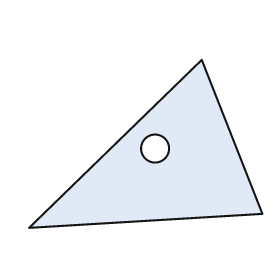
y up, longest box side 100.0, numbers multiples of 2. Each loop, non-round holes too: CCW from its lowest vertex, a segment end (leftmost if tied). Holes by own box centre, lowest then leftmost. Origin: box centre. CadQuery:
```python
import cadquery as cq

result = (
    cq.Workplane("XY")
    .moveTo(-50.0, -36.0)
    .lineTo(50.0, -30.0)
    .lineTo(24.0, 36.0)
    .close()
    .moveTo(4.0, -2.0)
    .circle(6.0)
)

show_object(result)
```